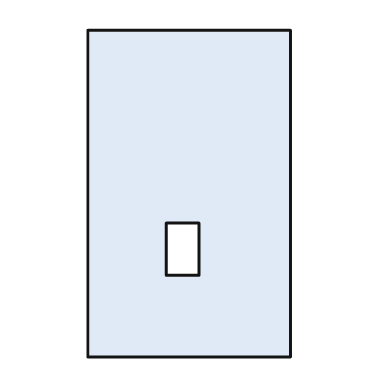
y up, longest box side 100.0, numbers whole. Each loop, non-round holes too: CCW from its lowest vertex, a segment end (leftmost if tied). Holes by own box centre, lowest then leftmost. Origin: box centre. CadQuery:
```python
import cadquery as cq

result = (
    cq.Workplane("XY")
    .moveTo(-31.0, -50.0)
    .lineTo(31.0, -50.0)
    .lineTo(31.0, 50.0)
    .lineTo(-31.0, 50.0)
    .close()
    .moveTo(-7.0, -25.0)
    .lineTo(3.0, -25.0)
    .lineTo(3.0, -9.0)
    .lineTo(-7.0, -9.0)
    .close()
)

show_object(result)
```